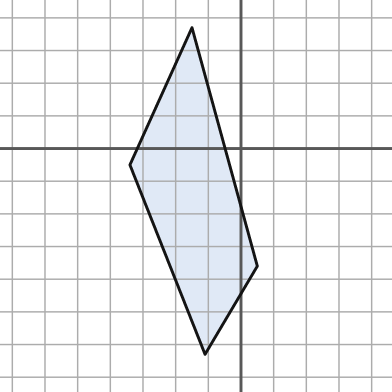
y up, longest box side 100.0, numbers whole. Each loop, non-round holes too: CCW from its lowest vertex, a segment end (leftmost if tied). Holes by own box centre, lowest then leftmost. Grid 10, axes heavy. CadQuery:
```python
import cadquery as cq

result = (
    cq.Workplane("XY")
    .moveTo(-11.0, -63.0)
    .lineTo(5.0, -36.0)
    .lineTo(-15.0, 37.0)
    .lineTo(-34.0, -5.0)
    .close()
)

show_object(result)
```